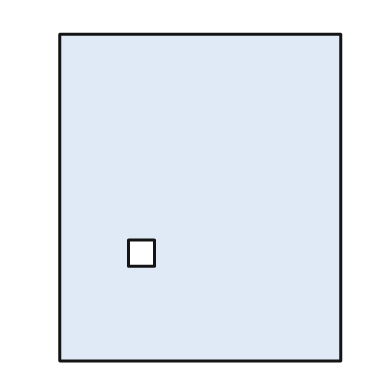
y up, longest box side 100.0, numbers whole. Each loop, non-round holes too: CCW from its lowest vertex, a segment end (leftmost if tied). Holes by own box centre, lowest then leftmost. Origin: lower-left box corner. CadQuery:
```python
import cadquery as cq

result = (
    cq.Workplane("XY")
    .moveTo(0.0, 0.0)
    .lineTo(86.0, 0.0)
    .lineTo(86.0, 100.0)
    .lineTo(0.0, 100.0)
    .close()
    .moveTo(21.0, 29.0)
    .lineTo(29.0, 29.0)
    .lineTo(29.0, 37.0)
    .lineTo(21.0, 37.0)
    .close()
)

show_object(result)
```